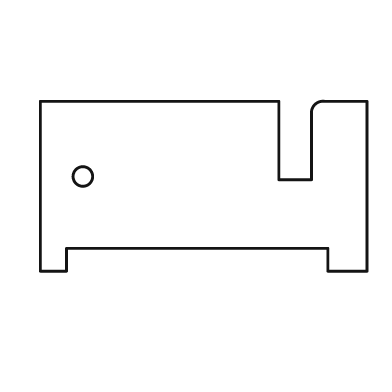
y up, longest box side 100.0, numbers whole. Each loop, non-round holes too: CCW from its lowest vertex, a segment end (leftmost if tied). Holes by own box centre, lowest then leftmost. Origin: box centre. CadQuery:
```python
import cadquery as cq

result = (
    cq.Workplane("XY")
    .moveTo(-50.0, -26.0)
    .lineTo(-42.0, -26.0)
    .lineTo(-42.0, -19.0)
    .lineTo(38.0, -19.0)
    .lineTo(38.0, -26.0)
    .lineTo(50.0, -26.0)
    .lineTo(50.0, 26.0)
    .lineTo(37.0, 26.0)
    .threePointArc((34.0, 25.0), (33.0, 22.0))
    .lineTo(33.0, 2.0)
    .lineTo(23.0, 2.0)
    .lineTo(23.0, 26.0)
    .lineTo(-50.0, 26.0)
    .close()
    .moveTo(-37.0, 3.0)
    .circle(3.0)
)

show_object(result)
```